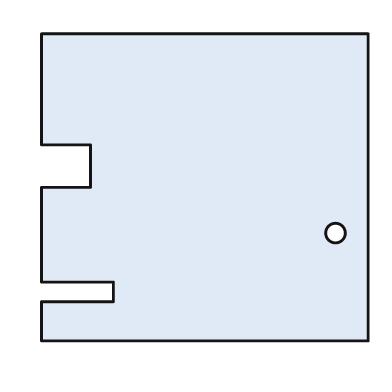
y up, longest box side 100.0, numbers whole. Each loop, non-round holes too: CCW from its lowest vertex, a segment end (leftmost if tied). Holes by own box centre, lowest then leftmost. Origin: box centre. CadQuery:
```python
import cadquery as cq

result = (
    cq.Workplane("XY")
    .moveTo(-50.0, -47.0)
    .lineTo(50.0, -47.0)
    .lineTo(50.0, 47.0)
    .lineTo(-50.0, 47.0)
    .lineTo(-50.0, 13.0)
    .lineTo(-35.0, 13.0)
    .lineTo(-35.0, 0.0)
    .lineTo(-50.0, 0.0)
    .lineTo(-50.0, -29.0)
    .lineTo(-28.0, -29.0)
    .lineTo(-28.0, -35.0)
    .lineTo(-50.0, -35.0)
    .close()
    .moveTo(40.0, -14.0)
    .circle(3.0)
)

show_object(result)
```